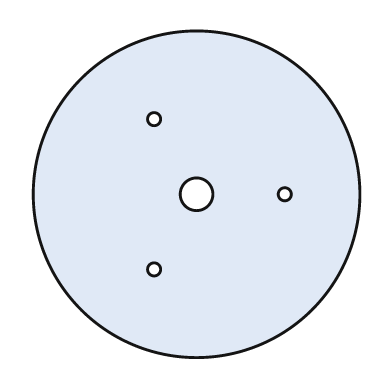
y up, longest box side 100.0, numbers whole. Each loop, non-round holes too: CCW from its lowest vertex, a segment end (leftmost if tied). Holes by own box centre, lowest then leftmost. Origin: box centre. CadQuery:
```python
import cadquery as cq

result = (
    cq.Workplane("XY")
    .moveTo(0.0, 0.0)
    .circle(50.0)
    .moveTo(-13.0, -23.0)
    .circle(2.0)
    .moveTo(0.0, 0.0)
    .circle(5.0)
    .moveTo(27.0, 0.0)
    .circle(2.0)
    .moveTo(-13.0, 23.0)
    .circle(2.0)
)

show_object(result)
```